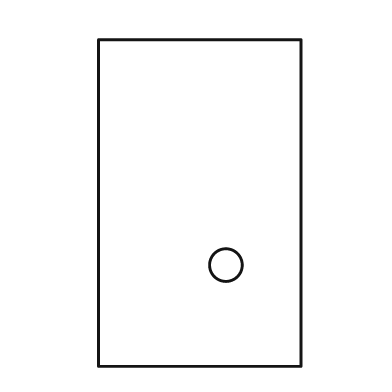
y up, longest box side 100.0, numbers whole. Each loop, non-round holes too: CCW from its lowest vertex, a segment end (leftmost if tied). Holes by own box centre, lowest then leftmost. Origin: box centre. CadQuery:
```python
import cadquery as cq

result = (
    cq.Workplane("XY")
    .moveTo(-31.0, -50.0)
    .lineTo(31.0, -50.0)
    .lineTo(31.0, 50.0)
    .lineTo(-31.0, 50.0)
    .close()
    .moveTo(8.0, -19.0)
    .circle(5.0)
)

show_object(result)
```